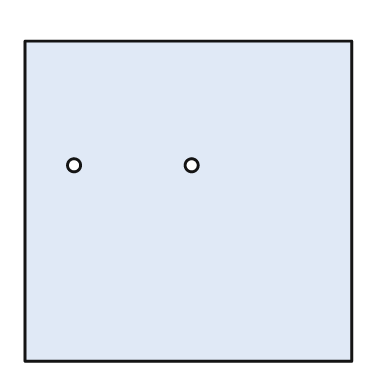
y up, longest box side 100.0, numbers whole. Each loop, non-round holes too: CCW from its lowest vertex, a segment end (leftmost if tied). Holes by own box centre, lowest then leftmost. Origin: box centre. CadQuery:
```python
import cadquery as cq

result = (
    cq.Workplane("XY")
    .moveTo(-50.0, -49.0)
    .lineTo(50.0, -49.0)
    .lineTo(50.0, 49.0)
    .lineTo(-50.0, 49.0)
    .close()
    .moveTo(-35.0, 11.0)
    .circle(2.0)
    .moveTo(1.0, 11.0)
    .circle(2.0)
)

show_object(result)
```